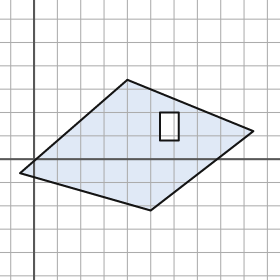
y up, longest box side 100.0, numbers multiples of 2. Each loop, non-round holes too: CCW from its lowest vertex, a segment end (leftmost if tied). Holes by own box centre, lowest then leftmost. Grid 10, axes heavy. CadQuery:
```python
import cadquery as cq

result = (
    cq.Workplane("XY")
    .moveTo(50.0, -22.0)
    .lineTo(94.0, 12.0)
    .lineTo(40.0, 34.0)
    .lineTo(-6.0, -6.0)
    .close()
    .moveTo(54.0, 8.0)
    .lineTo(62.0, 8.0)
    .lineTo(62.0, 20.0)
    .lineTo(54.0, 20.0)
    .close()
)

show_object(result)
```